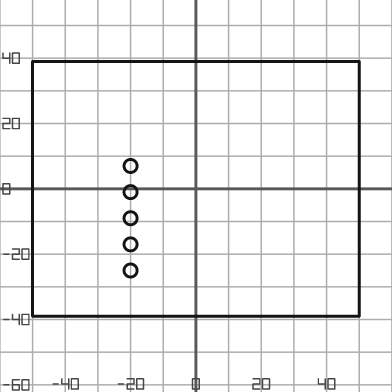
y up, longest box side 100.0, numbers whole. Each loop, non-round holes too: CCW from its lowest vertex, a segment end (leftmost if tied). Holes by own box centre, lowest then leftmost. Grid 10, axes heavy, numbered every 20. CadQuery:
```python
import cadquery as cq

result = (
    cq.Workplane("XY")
    .moveTo(-50.0, -39.0)
    .lineTo(50.0, -39.0)
    .lineTo(50.0, 39.0)
    .lineTo(-50.0, 39.0)
    .close()
    .moveTo(-20.0, -25.0)
    .circle(2.0)
    .moveTo(-20.0, -17.0)
    .circle(2.0)
    .moveTo(-20.0, -9.0)
    .circle(2.0)
    .moveTo(-20.0, -1.0)
    .circle(2.0)
    .moveTo(-20.0, 7.0)
    .circle(2.0)
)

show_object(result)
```